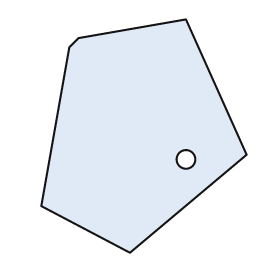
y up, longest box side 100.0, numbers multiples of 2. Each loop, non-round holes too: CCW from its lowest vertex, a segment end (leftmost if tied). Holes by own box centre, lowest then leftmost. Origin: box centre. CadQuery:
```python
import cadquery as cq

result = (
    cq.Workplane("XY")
    .moveTo(-6.0, -50.0)
    .lineTo(44.0, -8.0)
    .lineTo(18.0, 50.0)
    .lineTo(-28.0, 42.0)
    .lineTo(-32.0, 38.0)
    .lineTo(-44.0, -30.0)
    .close()
    .moveTo(18.0, -10.0)
    .circle(4.0)
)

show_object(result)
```